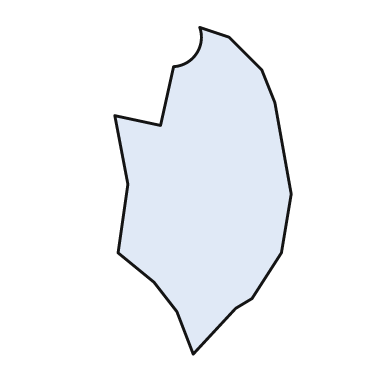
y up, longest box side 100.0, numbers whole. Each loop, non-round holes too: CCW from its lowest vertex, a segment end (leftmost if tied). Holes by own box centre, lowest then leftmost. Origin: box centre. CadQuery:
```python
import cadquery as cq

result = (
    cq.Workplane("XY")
    .moveTo(-3.0, -50.0)
    .lineTo(10.0, -36.0)
    .lineTo(15.0, -33.0)
    .lineTo(24.0, -19.0)
    .lineTo(27.0, -1.0)
    .lineTo(22.0, 27.0)
    .lineTo(18.0, 37.0)
    .lineTo(8.0, 47.0)
    .lineTo(-1.0, 50.0)
    .threePointArc((-2.0, 42.0), (-9.0, 38.0))
    .lineTo(-13.0, 20.0)
    .lineTo(-27.0, 23.0)
    .lineTo(-23.0, 2.0)
    .lineTo(-26.0, -19.0)
    .lineTo(-15.0, -28.0)
    .lineTo(-8.0, -37.0)
    .close()
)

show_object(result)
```